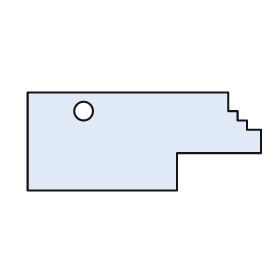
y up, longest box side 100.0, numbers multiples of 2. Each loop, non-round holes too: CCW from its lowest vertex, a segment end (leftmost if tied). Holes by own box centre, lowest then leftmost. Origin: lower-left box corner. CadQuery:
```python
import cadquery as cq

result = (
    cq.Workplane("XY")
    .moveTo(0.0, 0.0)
    .lineTo(64.0, 0.0)
    .lineTo(64.0, 16.0)
    .lineTo(100.0, 16.0)
    .lineTo(100.0, 26.0)
    .lineTo(94.0, 26.0)
    .lineTo(94.0, 30.0)
    .lineTo(90.0, 30.0)
    .lineTo(90.0, 34.0)
    .lineTo(86.0, 34.0)
    .lineTo(86.0, 42.0)
    .lineTo(0.0, 42.0)
    .close()
    .moveTo(24.0, 34.0)
    .circle(4.0)
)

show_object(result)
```